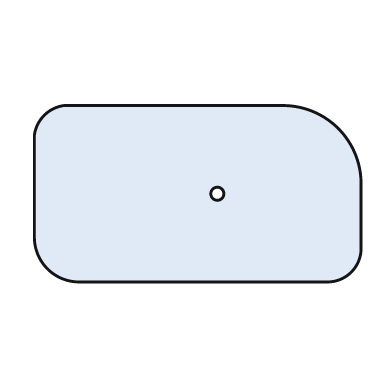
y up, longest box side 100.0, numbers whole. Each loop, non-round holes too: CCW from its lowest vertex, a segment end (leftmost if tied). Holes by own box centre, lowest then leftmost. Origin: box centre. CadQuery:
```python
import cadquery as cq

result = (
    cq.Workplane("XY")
    .moveTo(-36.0, -27.0)
    .lineTo(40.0, -27.0)
    .threePointArc((47.0, -24.0), (50.0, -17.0))
    .lineTo(50.0, 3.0)
    .threePointArc((43.0, 20.0), (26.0, 27.0))
    .lineTo(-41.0, 27.0)
    .threePointArc((-47.0, 24.0), (-50.0, 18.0))
    .lineTo(-50.0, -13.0)
    .threePointArc((-46.0, -23.0), (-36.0, -27.0))
    .close()
    .moveTo(6.0, 0.0)
    .circle(2.0)
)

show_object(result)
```